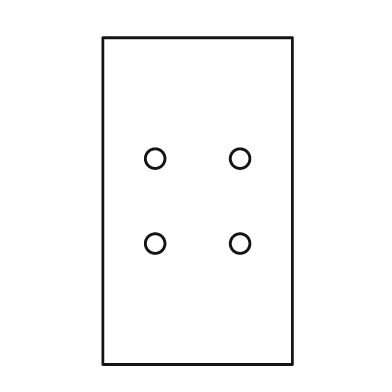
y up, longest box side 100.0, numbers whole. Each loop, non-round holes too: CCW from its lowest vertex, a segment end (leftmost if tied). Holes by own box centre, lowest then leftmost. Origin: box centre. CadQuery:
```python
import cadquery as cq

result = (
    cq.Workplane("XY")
    .moveTo(-29.0, -50.0)
    .lineTo(29.0, -50.0)
    .lineTo(29.0, 50.0)
    .lineTo(-29.0, 50.0)
    .close()
    .moveTo(-13.0, -13.0)
    .circle(3.0)
    .moveTo(13.0, -13.0)
    .circle(3.0)
    .moveTo(-13.0, 13.0)
    .circle(3.0)
    .moveTo(13.0, 13.0)
    .circle(3.0)
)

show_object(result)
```